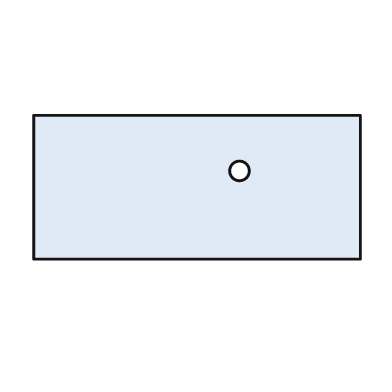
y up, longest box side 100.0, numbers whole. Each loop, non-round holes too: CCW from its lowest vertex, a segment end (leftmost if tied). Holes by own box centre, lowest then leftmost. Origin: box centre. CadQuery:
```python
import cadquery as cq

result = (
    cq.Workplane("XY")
    .moveTo(-50.0, -22.0)
    .lineTo(50.0, -22.0)
    .lineTo(50.0, 22.0)
    .lineTo(-50.0, 22.0)
    .close()
    .moveTo(13.0, 5.0)
    .circle(3.0)
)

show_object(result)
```